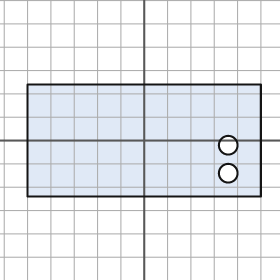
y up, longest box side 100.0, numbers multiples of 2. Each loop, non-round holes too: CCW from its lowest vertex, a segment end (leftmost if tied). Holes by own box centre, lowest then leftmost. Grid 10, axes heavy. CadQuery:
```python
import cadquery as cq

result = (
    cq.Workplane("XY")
    .moveTo(-50.0, -24.0)
    .lineTo(50.0, -24.0)
    .lineTo(50.0, 24.0)
    .lineTo(-50.0, 24.0)
    .close()
    .moveTo(36.0, -14.0)
    .circle(4.0)
    .moveTo(36.0, -2.0)
    .circle(4.0)
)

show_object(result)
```